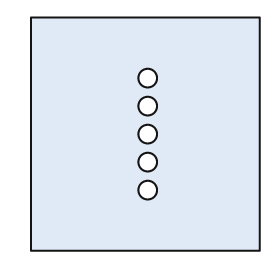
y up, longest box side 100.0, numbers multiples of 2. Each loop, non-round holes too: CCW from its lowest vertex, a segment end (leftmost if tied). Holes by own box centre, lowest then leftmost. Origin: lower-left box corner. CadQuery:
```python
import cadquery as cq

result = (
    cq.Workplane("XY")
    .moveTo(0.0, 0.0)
    .lineTo(98.0, 0.0)
    .lineTo(98.0, 100.0)
    .lineTo(0.0, 100.0)
    .close()
    .moveTo(50.0, 26.0)
    .circle(4.0)
    .moveTo(50.0, 38.0)
    .circle(4.0)
    .moveTo(50.0, 50.0)
    .circle(4.0)
    .moveTo(50.0, 62.0)
    .circle(4.0)
    .moveTo(50.0, 74.0)
    .circle(4.0)
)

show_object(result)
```